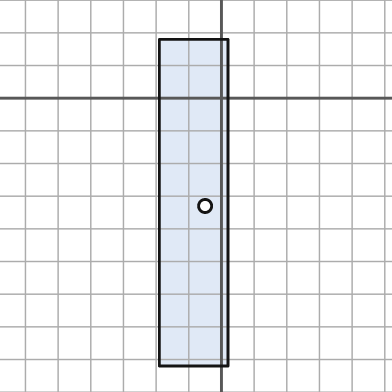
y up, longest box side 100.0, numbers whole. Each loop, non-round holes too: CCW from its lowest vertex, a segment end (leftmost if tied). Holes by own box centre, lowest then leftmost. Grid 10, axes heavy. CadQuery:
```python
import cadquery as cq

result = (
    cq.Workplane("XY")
    .moveTo(-19.0, -82.0)
    .lineTo(2.0, -82.0)
    .lineTo(2.0, 18.0)
    .lineTo(-19.0, 18.0)
    .close()
    .moveTo(-5.0, -33.0)
    .circle(2.0)
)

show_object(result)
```